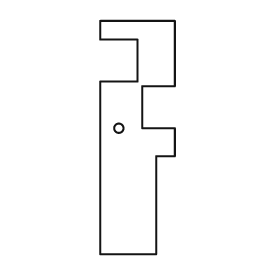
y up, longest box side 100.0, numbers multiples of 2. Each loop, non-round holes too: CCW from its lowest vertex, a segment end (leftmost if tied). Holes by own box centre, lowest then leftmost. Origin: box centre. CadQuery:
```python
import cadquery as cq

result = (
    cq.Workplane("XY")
    .moveTo(-16.0, -50.0)
    .lineTo(8.0, -50.0)
    .lineTo(8.0, -8.0)
    .lineTo(16.0, -8.0)
    .lineTo(16.0, 4.0)
    .lineTo(2.0, 4.0)
    .lineTo(2.0, 22.0)
    .lineTo(16.0, 22.0)
    .lineTo(16.0, 50.0)
    .lineTo(-16.0, 50.0)
    .lineTo(-16.0, 42.0)
    .lineTo(0.0, 42.0)
    .lineTo(0.0, 24.0)
    .lineTo(-16.0, 24.0)
    .close()
    .moveTo(-8.0, 4.0)
    .circle(2.0)
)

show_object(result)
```